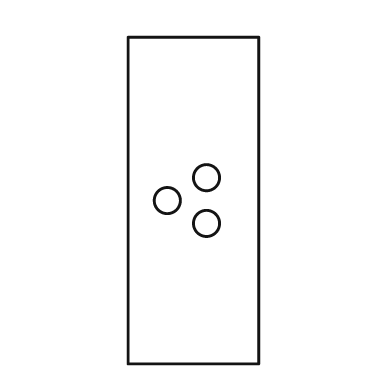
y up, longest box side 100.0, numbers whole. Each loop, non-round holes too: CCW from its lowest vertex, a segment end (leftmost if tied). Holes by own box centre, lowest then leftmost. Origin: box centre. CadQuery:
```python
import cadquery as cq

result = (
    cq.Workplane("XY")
    .moveTo(-20.0, -50.0)
    .lineTo(20.0, -50.0)
    .lineTo(20.0, 50.0)
    .lineTo(-20.0, 50.0)
    .close()
    .moveTo(4.0, -7.0)
    .circle(4.0)
    .moveTo(-8.0, 0.0)
    .circle(4.0)
    .moveTo(4.0, 7.0)
    .circle(4.0)
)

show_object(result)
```